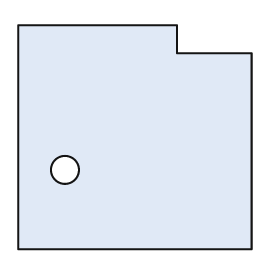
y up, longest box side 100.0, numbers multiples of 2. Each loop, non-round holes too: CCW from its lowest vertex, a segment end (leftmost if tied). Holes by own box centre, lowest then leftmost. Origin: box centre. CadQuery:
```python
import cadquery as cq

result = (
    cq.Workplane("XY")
    .moveTo(-50.0, -48.0)
    .lineTo(50.0, -48.0)
    .lineTo(50.0, 36.0)
    .lineTo(18.0, 36.0)
    .lineTo(18.0, 48.0)
    .lineTo(-50.0, 48.0)
    .close()
    .moveTo(-30.0, -14.0)
    .circle(6.0)
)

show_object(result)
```